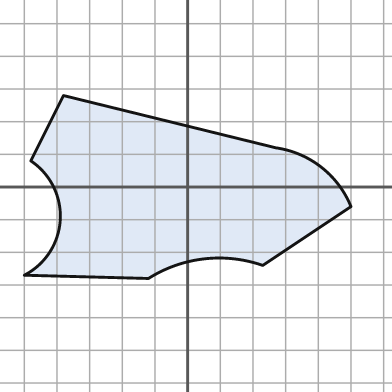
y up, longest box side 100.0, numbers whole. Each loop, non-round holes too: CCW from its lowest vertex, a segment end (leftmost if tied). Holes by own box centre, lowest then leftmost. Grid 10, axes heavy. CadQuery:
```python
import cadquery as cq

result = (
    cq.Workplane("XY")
    .moveTo(-12.0, -28.0)
    .threePointArc((5.0, -22.0), (23.0, -24.0))
    .lineTo(50.0, -6.0)
    .threePointArc((41.0, 6.0), (27.0, 12.0))
    .lineTo(-38.0, 28.0)
    .lineTo(-48.0, 8.0)
    .threePointArc((-39.0, -10.0), (-50.0, -27.0))
    .close()
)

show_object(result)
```